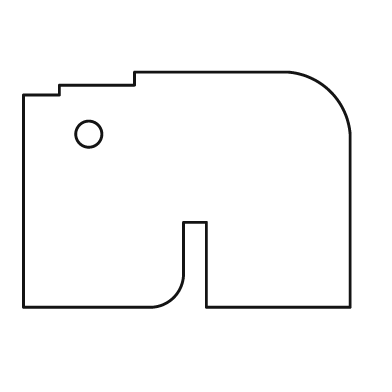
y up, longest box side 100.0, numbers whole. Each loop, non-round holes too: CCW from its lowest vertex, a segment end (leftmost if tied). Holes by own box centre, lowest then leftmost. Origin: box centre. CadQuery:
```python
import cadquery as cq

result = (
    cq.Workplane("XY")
    .moveTo(-50.0, -36.0)
    .lineTo(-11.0, -36.0)
    .threePointArc((-4.0, -33.0), (-1.0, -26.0))
    .lineTo(-1.0, -10.0)
    .lineTo(6.0, -10.0)
    .lineTo(6.0, -36.0)
    .lineTo(50.0, -36.0)
    .lineTo(50.0, 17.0)
    .threePointArc((44.0, 30.0), (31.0, 36.0))
    .lineTo(-16.0, 36.0)
    .lineTo(-16.0, 32.0)
    .lineTo(-39.0, 32.0)
    .lineTo(-39.0, 29.0)
    .lineTo(-50.0, 29.0)
    .close()
    .moveTo(-30.0, 17.0)
    .circle(4.0)
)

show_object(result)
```